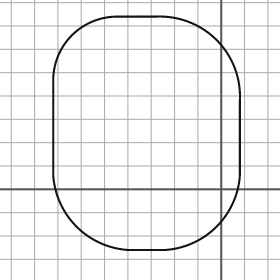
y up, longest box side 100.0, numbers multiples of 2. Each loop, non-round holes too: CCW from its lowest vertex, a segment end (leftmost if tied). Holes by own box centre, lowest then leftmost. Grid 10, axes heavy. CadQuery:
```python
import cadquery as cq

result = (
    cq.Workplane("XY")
    .moveTo(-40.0, -26.0)
    .lineTo(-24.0, -26.0)
    .threePointArc((-2.0, -16.0), (8.0, 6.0))
    .lineTo(8.0, 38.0)
    .threePointArc((-2.0, 64.0), (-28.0, 74.0))
    .lineTo(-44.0, 74.0)
    .threePointArc((-64.0, 66.0), (-72.0, 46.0))
    .lineTo(-72.0, 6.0)
    .threePointArc((-62.0, -16.0), (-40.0, -26.0))
    .close()
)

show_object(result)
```